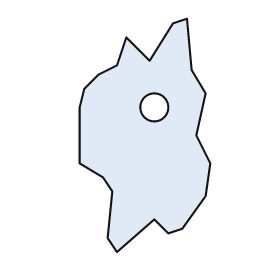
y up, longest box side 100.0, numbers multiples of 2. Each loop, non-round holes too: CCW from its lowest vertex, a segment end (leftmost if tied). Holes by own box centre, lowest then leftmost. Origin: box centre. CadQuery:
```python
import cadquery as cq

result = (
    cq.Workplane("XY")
    .moveTo(-12.0, -50.0)
    .lineTo(4.0, -36.0)
    .lineTo(10.0, -42.0)
    .lineTo(16.0, -40.0)
    .lineTo(26.0, -26.0)
    .lineTo(28.0, -12.0)
    .lineTo(22.0, 0.0)
    .lineTo(26.0, 18.0)
    .lineTo(20.0, 28.0)
    .lineTo(18.0, 50.0)
    .lineTo(12.0, 48.0)
    .lineTo(2.0, 32.0)
    .lineTo(-8.0, 42.0)
    .lineTo(-12.0, 30.0)
    .lineTo(-20.0, 26.0)
    .lineTo(-26.0, 20.0)
    .lineTo(-28.0, 12.0)
    .lineTo(-28.0, -12.0)
    .lineTo(-18.0, -18.0)
    .lineTo(-14.0, -24.0)
    .lineTo(-16.0, -44.0)
    .close()
    .moveTo(4.0, 12.0)
    .circle(6.0)
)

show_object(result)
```